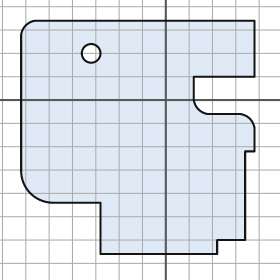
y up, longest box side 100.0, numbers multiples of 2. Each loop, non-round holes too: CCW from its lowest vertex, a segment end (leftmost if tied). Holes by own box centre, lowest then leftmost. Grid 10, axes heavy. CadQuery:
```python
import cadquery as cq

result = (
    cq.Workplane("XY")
    .moveTo(-28.0, -66.0)
    .lineTo(22.0, -66.0)
    .lineTo(22.0, -60.0)
    .lineTo(34.0, -60.0)
    .lineTo(34.0, -22.0)
    .lineTo(38.0, -22.0)
    .lineTo(38.0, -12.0)
    .threePointArc((36.0, -8.0), (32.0, -6.0))
    .lineTo(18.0, -6.0)
    .threePointArc((14.0, -4.0), (12.0, 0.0))
    .lineTo(12.0, 10.0)
    .lineTo(38.0, 10.0)
    .lineTo(38.0, 34.0)
    .lineTo(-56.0, 34.0)
    .threePointArc((-60.0, 32.0), (-62.0, 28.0))
    .lineTo(-62.0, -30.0)
    .threePointArc((-58.0, -40.0), (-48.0, -44.0))
    .lineTo(-28.0, -44.0)
    .close()
    .moveTo(-32.0, 20.0)
    .circle(4.0)
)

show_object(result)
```